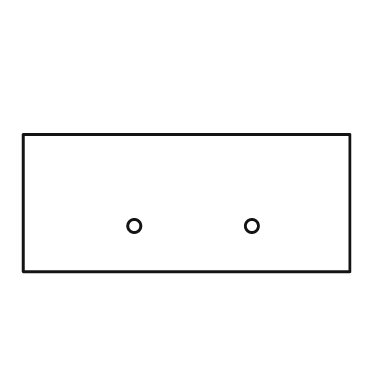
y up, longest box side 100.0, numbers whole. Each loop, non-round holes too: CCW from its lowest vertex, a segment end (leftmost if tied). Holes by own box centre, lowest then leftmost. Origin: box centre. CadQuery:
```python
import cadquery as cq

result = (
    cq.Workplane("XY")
    .moveTo(-50.0, -21.0)
    .lineTo(50.0, -21.0)
    .lineTo(50.0, 21.0)
    .lineTo(-50.0, 21.0)
    .close()
    .moveTo(-16.0, -7.0)
    .circle(2.0)
    .moveTo(20.0, -7.0)
    .circle(2.0)
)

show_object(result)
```